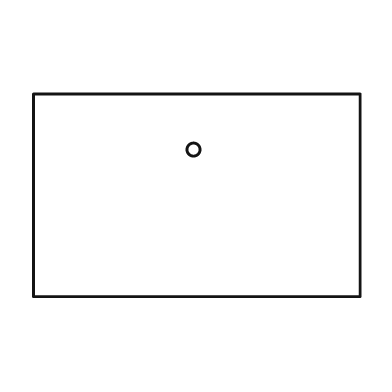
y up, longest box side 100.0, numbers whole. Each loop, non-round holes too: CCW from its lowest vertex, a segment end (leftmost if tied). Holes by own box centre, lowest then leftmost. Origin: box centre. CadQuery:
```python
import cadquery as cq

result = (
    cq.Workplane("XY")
    .moveTo(-50.0, -31.0)
    .lineTo(50.0, -31.0)
    .lineTo(50.0, 31.0)
    .lineTo(-50.0, 31.0)
    .close()
    .moveTo(-1.0, 14.0)
    .circle(2.0)
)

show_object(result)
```